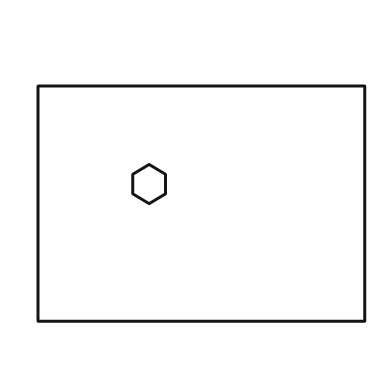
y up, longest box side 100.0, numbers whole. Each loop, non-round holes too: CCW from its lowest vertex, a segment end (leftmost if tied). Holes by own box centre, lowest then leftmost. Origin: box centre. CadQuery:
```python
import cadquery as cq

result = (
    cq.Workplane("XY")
    .moveTo(-50.0, -36.0)
    .lineTo(50.0, -36.0)
    .lineTo(50.0, 36.0)
    .lineTo(-50.0, 36.0)
    .close()
    .moveTo(-16.0, 0.0)
    .lineTo(-11.0, 3.0)
    .lineTo(-11.0, 9.0)
    .lineTo(-16.0, 12.0)
    .lineTo(-21.0, 9.0)
    .lineTo(-21.0, 3.0)
    .close()
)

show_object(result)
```